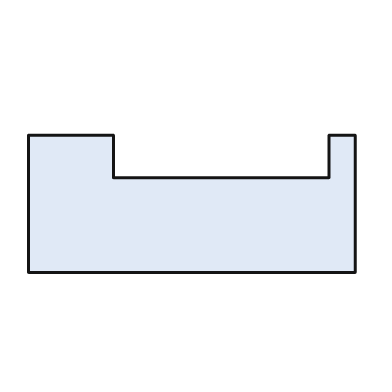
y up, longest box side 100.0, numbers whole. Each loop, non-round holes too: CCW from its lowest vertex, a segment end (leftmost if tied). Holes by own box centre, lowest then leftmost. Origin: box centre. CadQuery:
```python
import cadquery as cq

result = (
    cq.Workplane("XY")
    .moveTo(-50.0, -21.0)
    .lineTo(50.0, -21.0)
    .lineTo(50.0, 21.0)
    .lineTo(42.0, 21.0)
    .lineTo(42.0, 8.0)
    .lineTo(-24.0, 8.0)
    .lineTo(-24.0, 21.0)
    .lineTo(-50.0, 21.0)
    .close()
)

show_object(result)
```